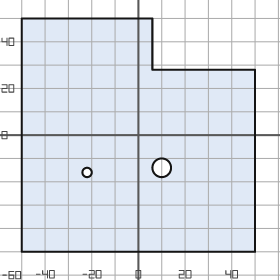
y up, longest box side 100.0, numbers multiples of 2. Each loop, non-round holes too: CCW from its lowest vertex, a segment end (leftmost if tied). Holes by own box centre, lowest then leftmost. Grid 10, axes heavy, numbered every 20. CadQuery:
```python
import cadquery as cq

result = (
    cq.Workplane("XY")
    .moveTo(-50.0, -50.0)
    .lineTo(50.0, -50.0)
    .lineTo(50.0, 28.0)
    .lineTo(6.0, 28.0)
    .lineTo(6.0, 50.0)
    .lineTo(-50.0, 50.0)
    .close()
    .moveTo(-22.0, -16.0)
    .circle(2.0)
    .moveTo(10.0, -14.0)
    .circle(4.0)
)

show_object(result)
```